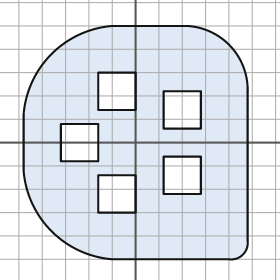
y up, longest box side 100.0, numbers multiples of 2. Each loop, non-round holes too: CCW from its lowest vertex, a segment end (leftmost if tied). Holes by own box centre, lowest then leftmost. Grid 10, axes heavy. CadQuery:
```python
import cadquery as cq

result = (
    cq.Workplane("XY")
    .moveTo(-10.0, -50.0)
    .lineTo(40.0, -50.0)
    .threePointArc((46.0, -48.0), (48.0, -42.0))
    .lineTo(48.0, 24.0)
    .threePointArc((40.0, 42.0), (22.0, 50.0))
    .lineTo(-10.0, 50.0)
    .threePointArc((-36.0, 38.0), (-48.0, 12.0))
    .lineTo(-48.0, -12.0)
    .threePointArc((-36.0, -38.0), (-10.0, -50.0))
    .close()
    .moveTo(-16.0, -30.0)
    .lineTo(0.0, -30.0)
    .lineTo(0.0, -14.0)
    .lineTo(-16.0, -14.0)
    .close()
    .moveTo(12.0, -22.0)
    .lineTo(28.0, -22.0)
    .lineTo(28.0, -6.0)
    .lineTo(12.0, -6.0)
    .close()
    .moveTo(-32.0, -8.0)
    .lineTo(-16.0, -8.0)
    .lineTo(-16.0, 8.0)
    .lineTo(-32.0, 8.0)
    .close()
    .moveTo(12.0, 6.0)
    .lineTo(28.0, 6.0)
    .lineTo(28.0, 22.0)
    .lineTo(12.0, 22.0)
    .close()
    .moveTo(-16.0, 14.0)
    .lineTo(0.0, 14.0)
    .lineTo(0.0, 30.0)
    .lineTo(-16.0, 30.0)
    .close()
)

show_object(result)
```